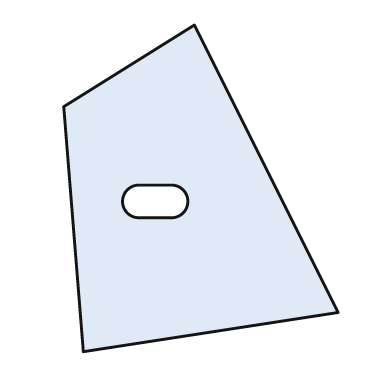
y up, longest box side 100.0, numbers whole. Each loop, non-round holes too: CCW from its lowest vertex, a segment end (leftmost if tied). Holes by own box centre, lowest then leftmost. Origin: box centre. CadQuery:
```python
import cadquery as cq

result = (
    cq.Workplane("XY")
    .moveTo(-36.0, -50.0)
    .lineTo(42.0, -38.0)
    .lineTo(-2.0, 50.0)
    .lineTo(-42.0, 25.0)
    .close()
    .moveTo(-19.0, -9.0)
    .lineTo(-9.0, -9.0)
    .threePointArc((-4.0, -4.0), (-9.0, 1.0))
    .lineTo(-19.0, 1.0)
    .threePointArc((-24.0, -4.0), (-19.0, -9.0))
    .close()
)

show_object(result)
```